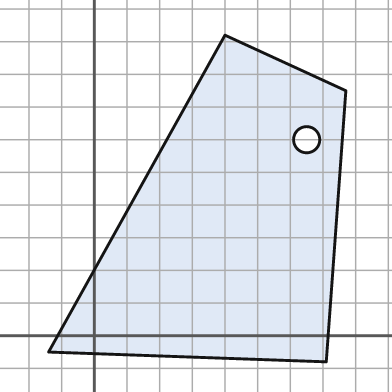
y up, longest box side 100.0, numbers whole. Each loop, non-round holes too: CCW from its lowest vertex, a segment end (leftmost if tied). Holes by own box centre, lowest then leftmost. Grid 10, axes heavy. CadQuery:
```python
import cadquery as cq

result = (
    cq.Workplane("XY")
    .moveTo(71.0, -8.0)
    .lineTo(77.0, 75.0)
    .lineTo(40.0, 92.0)
    .lineTo(-14.0, -5.0)
    .close()
    .moveTo(65.0, 60.0)
    .circle(4.0)
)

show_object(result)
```